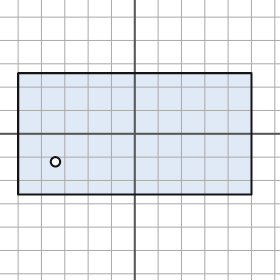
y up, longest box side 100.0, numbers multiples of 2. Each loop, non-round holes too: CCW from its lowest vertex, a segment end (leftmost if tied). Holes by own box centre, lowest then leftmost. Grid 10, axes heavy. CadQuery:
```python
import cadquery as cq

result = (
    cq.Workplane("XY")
    .moveTo(-50.0, -26.0)
    .lineTo(50.0, -26.0)
    .lineTo(50.0, 26.0)
    .lineTo(-50.0, 26.0)
    .close()
    .moveTo(-34.0, -12.0)
    .circle(2.0)
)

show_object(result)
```